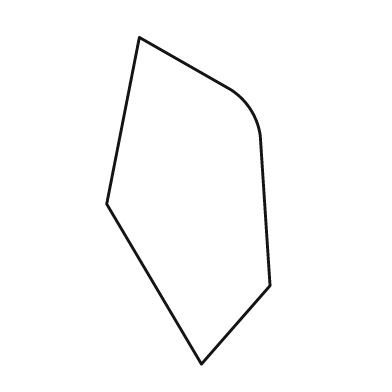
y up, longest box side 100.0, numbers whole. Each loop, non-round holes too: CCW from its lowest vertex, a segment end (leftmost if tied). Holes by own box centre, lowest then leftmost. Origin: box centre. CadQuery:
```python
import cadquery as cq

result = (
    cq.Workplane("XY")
    .moveTo(4.0, -50.0)
    .lineTo(25.0, -26.0)
    .lineTo(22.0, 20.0)
    .threePointArc((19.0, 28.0), (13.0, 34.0))
    .lineTo(-15.0, 50.0)
    .lineTo(-25.0, -1.0)
    .close()
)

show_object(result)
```